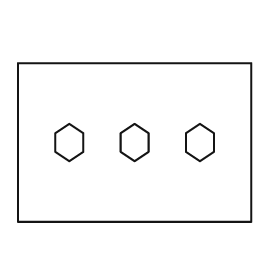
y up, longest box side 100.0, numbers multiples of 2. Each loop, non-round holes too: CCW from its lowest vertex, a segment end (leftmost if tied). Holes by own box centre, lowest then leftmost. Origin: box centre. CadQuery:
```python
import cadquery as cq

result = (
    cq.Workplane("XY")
    .moveTo(-50.0, -34.0)
    .lineTo(50.0, -34.0)
    .lineTo(50.0, 34.0)
    .lineTo(-50.0, 34.0)
    .close()
    .moveTo(-28.0, -8.0)
    .lineTo(-22.0, -4.0)
    .lineTo(-22.0, 4.0)
    .lineTo(-28.0, 8.0)
    .lineTo(-34.0, 4.0)
    .lineTo(-34.0, -4.0)
    .close()
    .moveTo(0.0, -8.0)
    .lineTo(6.0, -4.0)
    .lineTo(6.0, 4.0)
    .lineTo(0.0, 8.0)
    .lineTo(-6.0, 4.0)
    .lineTo(-6.0, -4.0)
    .close()
    .moveTo(28.0, -8.0)
    .lineTo(34.0, -4.0)
    .lineTo(34.0, 4.0)
    .lineTo(28.0, 8.0)
    .lineTo(22.0, 4.0)
    .lineTo(22.0, -4.0)
    .close()
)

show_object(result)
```